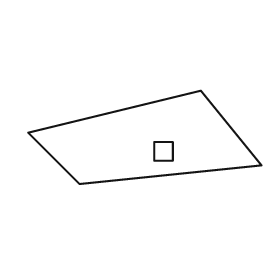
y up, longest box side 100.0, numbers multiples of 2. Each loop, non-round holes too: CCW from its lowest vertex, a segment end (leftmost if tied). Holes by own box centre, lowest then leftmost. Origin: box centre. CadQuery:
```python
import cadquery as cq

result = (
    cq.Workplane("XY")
    .moveTo(-28.0, -20.0)
    .lineTo(50.0, -12.0)
    .lineTo(24.0, 20.0)
    .lineTo(-50.0, 2.0)
    .close()
    .moveTo(4.0, -10.0)
    .lineTo(12.0, -10.0)
    .lineTo(12.0, -2.0)
    .lineTo(4.0, -2.0)
    .close()
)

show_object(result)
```